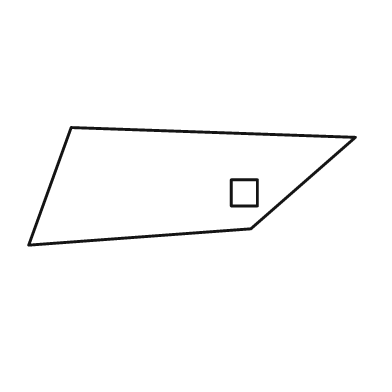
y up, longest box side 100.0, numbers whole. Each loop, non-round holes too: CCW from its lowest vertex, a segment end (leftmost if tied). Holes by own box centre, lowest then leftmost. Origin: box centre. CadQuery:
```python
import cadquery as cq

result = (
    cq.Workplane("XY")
    .moveTo(-50.0, -18.0)
    .lineTo(18.0, -13.0)
    .lineTo(50.0, 15.0)
    .lineTo(-37.0, 18.0)
    .close()
    .moveTo(12.0, -6.0)
    .lineTo(20.0, -6.0)
    .lineTo(20.0, 2.0)
    .lineTo(12.0, 2.0)
    .close()
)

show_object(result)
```